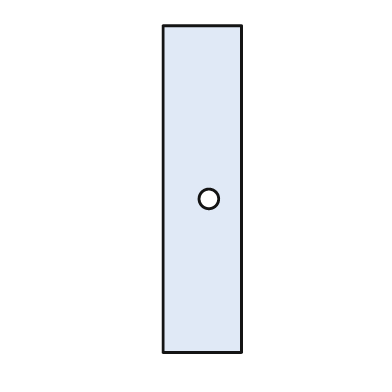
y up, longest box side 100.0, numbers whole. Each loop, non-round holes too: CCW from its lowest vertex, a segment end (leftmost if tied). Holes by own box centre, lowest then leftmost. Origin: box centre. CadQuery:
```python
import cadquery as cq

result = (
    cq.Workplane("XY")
    .moveTo(-12.0, -50.0)
    .lineTo(12.0, -50.0)
    .lineTo(12.0, 50.0)
    .lineTo(-12.0, 50.0)
    .close()
    .moveTo(2.0, -3.0)
    .circle(3.0)
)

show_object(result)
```